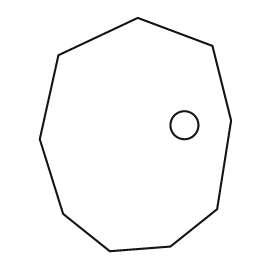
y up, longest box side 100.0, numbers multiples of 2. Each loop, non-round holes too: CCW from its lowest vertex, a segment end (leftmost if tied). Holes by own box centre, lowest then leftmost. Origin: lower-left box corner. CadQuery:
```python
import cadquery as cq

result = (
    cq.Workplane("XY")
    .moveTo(30.0, 0.0)
    .lineTo(56.0, 2.0)
    .lineTo(76.0, 18.0)
    .lineTo(82.0, 56.0)
    .lineTo(74.0, 88.0)
    .lineTo(42.0, 100.0)
    .lineTo(8.0, 84.0)
    .lineTo(0.0, 48.0)
    .lineTo(10.0, 16.0)
    .close()
    .moveTo(62.0, 54.0)
    .circle(6.0)
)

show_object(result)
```